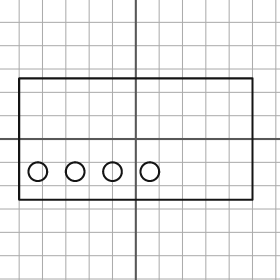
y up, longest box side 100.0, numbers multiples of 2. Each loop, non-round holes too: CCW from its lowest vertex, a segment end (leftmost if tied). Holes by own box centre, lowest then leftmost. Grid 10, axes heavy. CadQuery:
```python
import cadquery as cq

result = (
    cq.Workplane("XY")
    .moveTo(-50.0, -26.0)
    .lineTo(50.0, -26.0)
    .lineTo(50.0, 26.0)
    .lineTo(-50.0, 26.0)
    .close()
    .moveTo(-42.0, -14.0)
    .circle(4.0)
    .moveTo(-26.0, -14.0)
    .circle(4.0)
    .moveTo(-10.0, -14.0)
    .circle(4.0)
    .moveTo(6.0, -14.0)
    .circle(4.0)
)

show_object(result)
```